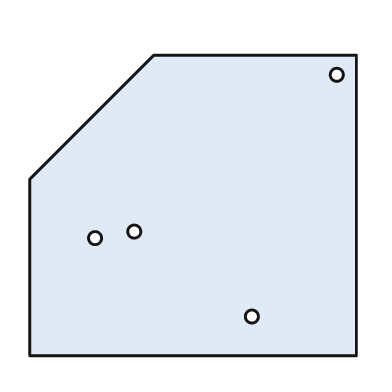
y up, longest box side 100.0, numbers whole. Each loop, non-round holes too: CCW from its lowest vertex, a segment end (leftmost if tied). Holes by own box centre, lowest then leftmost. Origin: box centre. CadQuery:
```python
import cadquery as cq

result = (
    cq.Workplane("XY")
    .moveTo(-50.0, -46.0)
    .lineTo(50.0, -46.0)
    .lineTo(50.0, 46.0)
    .lineTo(-12.0, 46.0)
    .lineTo(-50.0, 8.0)
    .close()
    .moveTo(18.0, -34.0)
    .circle(2.0)
    .moveTo(-30.0, -10.0)
    .circle(2.0)
    .moveTo(-18.0, -8.0)
    .circle(2.0)
    .moveTo(44.0, 40.0)
    .circle(2.0)
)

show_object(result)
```